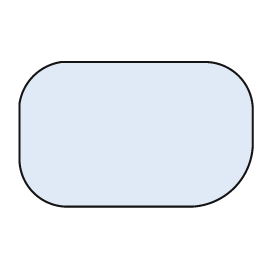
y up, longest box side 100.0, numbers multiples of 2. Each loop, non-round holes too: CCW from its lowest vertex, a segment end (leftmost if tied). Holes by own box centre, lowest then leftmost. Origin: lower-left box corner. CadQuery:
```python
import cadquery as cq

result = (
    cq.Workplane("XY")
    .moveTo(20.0, 0.0)
    .lineTo(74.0, 0.0)
    .threePointArc((92.0, 8.0), (100.0, 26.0))
    .lineTo(100.0, 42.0)
    .threePointArc((94.0, 56.0), (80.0, 62.0))
    .lineTo(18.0, 62.0)
    .threePointArc((6.0, 56.0), (0.0, 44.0))
    .lineTo(0.0, 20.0)
    .threePointArc((6.0, 6.0), (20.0, 0.0))
    .close()
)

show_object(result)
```